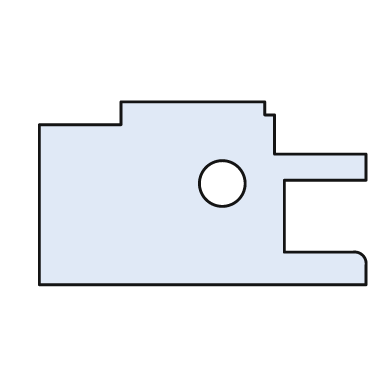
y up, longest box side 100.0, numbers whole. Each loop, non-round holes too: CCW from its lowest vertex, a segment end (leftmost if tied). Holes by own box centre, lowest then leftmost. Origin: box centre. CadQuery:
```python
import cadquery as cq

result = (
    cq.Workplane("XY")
    .moveTo(-50.0, -28.0)
    .lineTo(50.0, -28.0)
    .lineTo(50.0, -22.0)
    .threePointArc((49.0, -19.0), (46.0, -18.0))
    .lineTo(25.0, -18.0)
    .lineTo(25.0, 4.0)
    .lineTo(50.0, 4.0)
    .lineTo(50.0, 12.0)
    .lineTo(22.0, 12.0)
    .lineTo(22.0, 24.0)
    .lineTo(19.0, 24.0)
    .lineTo(19.0, 28.0)
    .lineTo(-25.0, 28.0)
    .lineTo(-25.0, 21.0)
    .lineTo(-50.0, 21.0)
    .close()
    .moveTo(6.0, 3.0)
    .circle(7.0)
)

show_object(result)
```